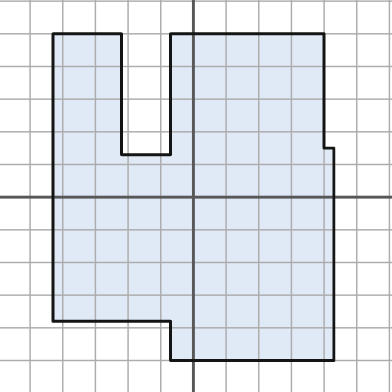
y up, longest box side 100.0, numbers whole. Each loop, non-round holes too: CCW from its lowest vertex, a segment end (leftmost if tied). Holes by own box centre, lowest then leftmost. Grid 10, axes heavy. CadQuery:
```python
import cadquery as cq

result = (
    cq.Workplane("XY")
    .moveTo(-7.0, -50.0)
    .lineTo(43.0, -50.0)
    .lineTo(43.0, 15.0)
    .lineTo(40.0, 15.0)
    .lineTo(40.0, 50.0)
    .lineTo(-7.0, 50.0)
    .lineTo(-7.0, 13.0)
    .lineTo(-22.0, 13.0)
    .lineTo(-22.0, 50.0)
    .lineTo(-43.0, 50.0)
    .lineTo(-43.0, -38.0)
    .lineTo(-7.0, -38.0)
    .close()
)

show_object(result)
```